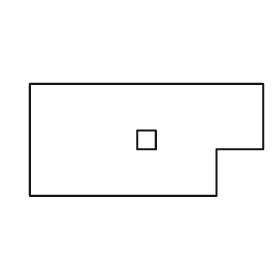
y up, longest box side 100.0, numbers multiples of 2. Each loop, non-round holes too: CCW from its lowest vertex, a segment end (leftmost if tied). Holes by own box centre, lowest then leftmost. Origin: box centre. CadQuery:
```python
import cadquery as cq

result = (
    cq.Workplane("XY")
    .moveTo(-50.0, -24.0)
    .lineTo(30.0, -24.0)
    .lineTo(30.0, -4.0)
    .lineTo(50.0, -4.0)
    .lineTo(50.0, 24.0)
    .lineTo(-50.0, 24.0)
    .close()
    .moveTo(-4.0, -4.0)
    .lineTo(4.0, -4.0)
    .lineTo(4.0, 4.0)
    .lineTo(-4.0, 4.0)
    .close()
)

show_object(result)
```